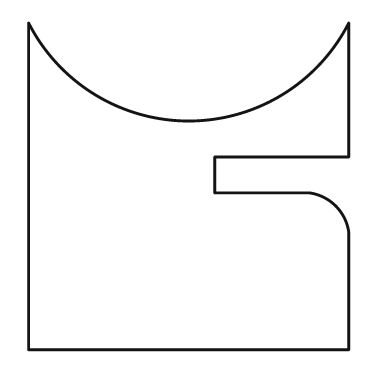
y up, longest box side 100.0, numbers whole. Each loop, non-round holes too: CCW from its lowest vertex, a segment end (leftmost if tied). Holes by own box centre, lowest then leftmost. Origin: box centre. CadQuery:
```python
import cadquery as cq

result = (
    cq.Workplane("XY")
    .moveTo(-49.0, -50.0)
    .lineTo(49.0, -50.0)
    .lineTo(49.0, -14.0)
    .threePointArc((45.0, -6.0), (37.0, -2.0))
    .lineTo(8.0, -2.0)
    .lineTo(8.0, 9.0)
    .lineTo(49.0, 9.0)
    .lineTo(49.0, 50.0)
    .threePointArc((0.0, 20.0), (-49.0, 50.0))
    .close()
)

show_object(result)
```